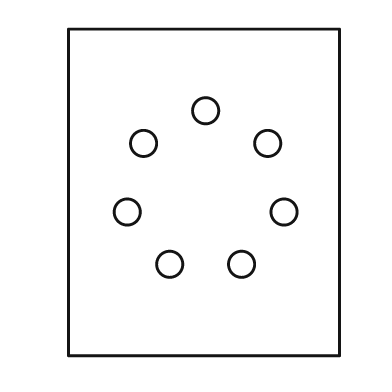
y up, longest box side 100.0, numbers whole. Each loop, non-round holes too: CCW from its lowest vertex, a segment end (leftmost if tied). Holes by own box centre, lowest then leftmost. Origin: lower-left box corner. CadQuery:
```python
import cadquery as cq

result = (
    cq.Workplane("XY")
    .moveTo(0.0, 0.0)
    .lineTo(83.0, 0.0)
    .lineTo(83.0, 100.0)
    .lineTo(0.0, 100.0)
    .close()
    .moveTo(31.0, 28.0)
    .circle(4.0)
    .moveTo(53.0, 28.0)
    .circle(4.0)
    .moveTo(18.0, 44.0)
    .circle(4.0)
    .moveTo(66.0, 44.0)
    .circle(4.0)
    .moveTo(23.0, 65.0)
    .circle(4.0)
    .moveTo(61.0, 65.0)
    .circle(4.0)
    .moveTo(42.0, 75.0)
    .circle(4.0)
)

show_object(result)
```